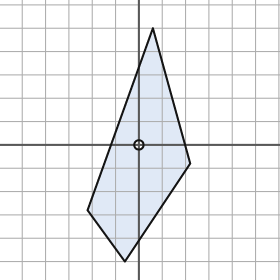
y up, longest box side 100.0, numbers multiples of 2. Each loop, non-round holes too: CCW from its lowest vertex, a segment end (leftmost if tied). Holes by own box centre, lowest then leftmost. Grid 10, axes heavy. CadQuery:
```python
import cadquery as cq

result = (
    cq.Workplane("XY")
    .moveTo(-6.0, -50.0)
    .lineTo(22.0, -8.0)
    .lineTo(6.0, 50.0)
    .lineTo(-22.0, -28.0)
    .close()
    .moveTo(0.0, 0.0)
    .circle(2.0)
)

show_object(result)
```